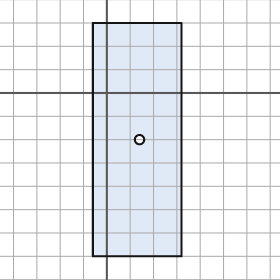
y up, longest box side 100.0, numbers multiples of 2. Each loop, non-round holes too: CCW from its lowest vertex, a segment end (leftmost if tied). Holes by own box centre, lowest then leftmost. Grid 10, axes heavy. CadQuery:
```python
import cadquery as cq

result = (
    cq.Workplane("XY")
    .moveTo(-6.0, -70.0)
    .lineTo(32.0, -70.0)
    .lineTo(32.0, 30.0)
    .lineTo(-6.0, 30.0)
    .close()
    .moveTo(14.0, -20.0)
    .circle(2.0)
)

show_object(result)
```